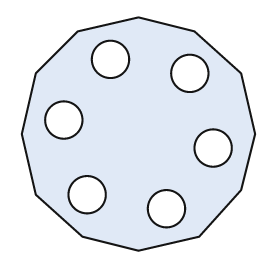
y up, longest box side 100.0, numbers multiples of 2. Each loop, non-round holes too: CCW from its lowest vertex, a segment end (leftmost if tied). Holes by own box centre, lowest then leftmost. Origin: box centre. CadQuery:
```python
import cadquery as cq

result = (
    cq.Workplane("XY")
    .moveTo(0.0, -50.0)
    .lineTo(26.0, -44.0)
    .lineTo(44.0, -24.0)
    .lineTo(50.0, 0.0)
    .lineTo(44.0, 26.0)
    .lineTo(24.0, 44.0)
    .lineTo(0.0, 50.0)
    .lineTo(-26.0, 44.0)
    .lineTo(-44.0, 26.0)
    .lineTo(-50.0, 0.0)
    .lineTo(-44.0, -26.0)
    .lineTo(-24.0, -44.0)
    .close()
    .moveTo(12.0, -32.0)
    .circle(8.0)
    .moveTo(-22.0, -26.0)
    .circle(8.0)
    .moveTo(32.0, -6.0)
    .circle(8.0)
    .moveTo(-32.0, 6.0)
    .circle(8.0)
    .moveTo(22.0, 26.0)
    .circle(8.0)
    .moveTo(-12.0, 32.0)
    .circle(8.0)
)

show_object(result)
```